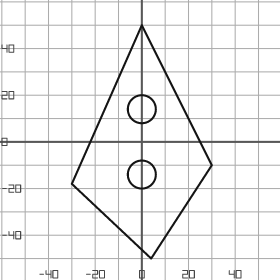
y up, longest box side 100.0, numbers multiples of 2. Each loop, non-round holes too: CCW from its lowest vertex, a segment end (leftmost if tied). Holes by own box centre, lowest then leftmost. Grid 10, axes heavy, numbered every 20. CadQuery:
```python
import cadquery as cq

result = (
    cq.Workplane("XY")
    .moveTo(4.0, -50.0)
    .lineTo(30.0, -10.0)
    .lineTo(0.0, 50.0)
    .lineTo(-30.0, -18.0)
    .close()
    .moveTo(0.0, -14.0)
    .circle(6.0)
    .moveTo(0.0, 14.0)
    .circle(6.0)
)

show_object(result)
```